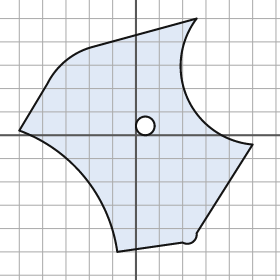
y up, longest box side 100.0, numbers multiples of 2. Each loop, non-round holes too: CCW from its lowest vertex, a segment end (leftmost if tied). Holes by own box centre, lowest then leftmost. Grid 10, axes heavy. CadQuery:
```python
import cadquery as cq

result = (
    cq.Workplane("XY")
    .moveTo(-8.0, -50.0)
    .lineTo(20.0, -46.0)
    .threePointArc((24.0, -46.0), (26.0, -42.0))
    .lineTo(50.0, -4.0)
    .threePointArc((22.0, 16.0), (26.0, 50.0))
    .lineTo(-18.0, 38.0)
    .threePointArc((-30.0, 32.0), (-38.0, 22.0))
    .lineTo(-50.0, 2.0)
    .threePointArc((-22.0, -18.0), (-8.0, -50.0))
    .close()
    .moveTo(4.0, 4.0)
    .circle(4.0)
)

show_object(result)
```